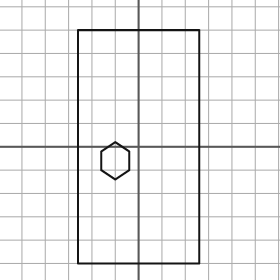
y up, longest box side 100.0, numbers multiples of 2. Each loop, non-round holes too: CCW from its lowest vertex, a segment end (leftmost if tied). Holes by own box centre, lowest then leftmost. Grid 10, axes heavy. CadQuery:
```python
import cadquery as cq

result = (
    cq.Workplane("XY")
    .moveTo(-26.0, -50.0)
    .lineTo(26.0, -50.0)
    .lineTo(26.0, 50.0)
    .lineTo(-26.0, 50.0)
    .close()
    .moveTo(-10.0, -14.0)
    .lineTo(-4.0, -10.0)
    .lineTo(-4.0, -2.0)
    .lineTo(-10.0, 2.0)
    .lineTo(-16.0, -2.0)
    .lineTo(-16.0, -10.0)
    .close()
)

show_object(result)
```